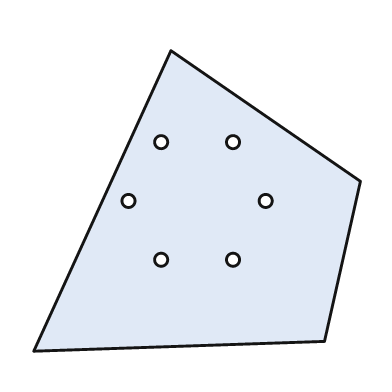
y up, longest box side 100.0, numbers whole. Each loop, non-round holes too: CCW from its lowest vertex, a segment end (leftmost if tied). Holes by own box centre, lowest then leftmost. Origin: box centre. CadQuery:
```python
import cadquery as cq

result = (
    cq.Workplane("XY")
    .moveTo(-50.0, -46.0)
    .lineTo(39.0, -43.0)
    .lineTo(50.0, 6.0)
    .lineTo(-8.0, 46.0)
    .close()
    .moveTo(-11.0, -18.0)
    .circle(2.0)
    .moveTo(11.0, -18.0)
    .circle(2.0)
    .moveTo(-21.0, 0.0)
    .circle(2.0)
    .moveTo(21.0, 0.0)
    .circle(2.0)
    .moveTo(-11.0, 18.0)
    .circle(2.0)
    .moveTo(11.0, 18.0)
    .circle(2.0)
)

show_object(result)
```